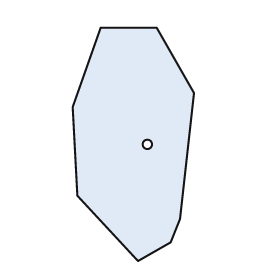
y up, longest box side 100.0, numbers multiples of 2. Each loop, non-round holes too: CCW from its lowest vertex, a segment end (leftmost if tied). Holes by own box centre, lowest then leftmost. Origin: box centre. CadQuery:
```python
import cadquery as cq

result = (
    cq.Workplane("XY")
    .moveTo(2.0, -50.0)
    .lineTo(16.0, -42.0)
    .lineTo(20.0, -32.0)
    .lineTo(26.0, 22.0)
    .lineTo(10.0, 50.0)
    .lineTo(-14.0, 50.0)
    .lineTo(-26.0, 16.0)
    .lineTo(-24.0, -22.0)
    .close()
    .moveTo(6.0, 0.0)
    .circle(2.0)
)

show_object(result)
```